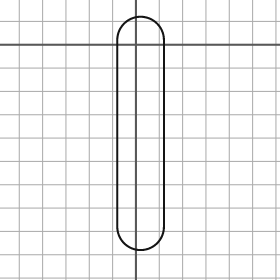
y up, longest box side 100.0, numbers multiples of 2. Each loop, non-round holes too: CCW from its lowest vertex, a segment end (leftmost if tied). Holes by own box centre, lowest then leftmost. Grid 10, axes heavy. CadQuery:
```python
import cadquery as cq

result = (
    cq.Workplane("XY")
    .moveTo(-8.0, -78.0)
    .threePointArc((2.0, -88.0), (12.0, -78.0))
    .lineTo(12.0, 2.0)
    .threePointArc((2.0, 12.0), (-8.0, 2.0))
    .close()
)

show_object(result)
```